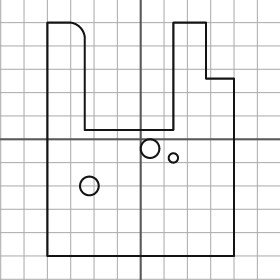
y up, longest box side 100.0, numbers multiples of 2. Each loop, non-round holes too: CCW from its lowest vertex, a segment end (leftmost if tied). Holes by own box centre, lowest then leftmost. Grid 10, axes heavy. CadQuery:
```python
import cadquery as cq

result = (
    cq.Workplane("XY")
    .moveTo(-40.0, -50.0)
    .lineTo(40.0, -50.0)
    .lineTo(40.0, 26.0)
    .lineTo(28.0, 26.0)
    .lineTo(28.0, 50.0)
    .lineTo(14.0, 50.0)
    .lineTo(14.0, 4.0)
    .lineTo(-24.0, 4.0)
    .lineTo(-24.0, 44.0)
    .threePointArc((-26.0, 48.0), (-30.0, 50.0))
    .lineTo(-40.0, 50.0)
    .close()
    .moveTo(-22.0, -20.0)
    .circle(4.0)
    .moveTo(14.0, -8.0)
    .circle(2.0)
    .moveTo(4.0, -4.0)
    .circle(4.0)
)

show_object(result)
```